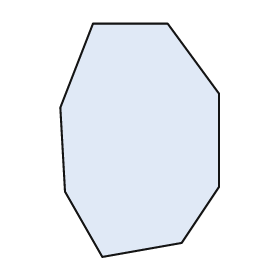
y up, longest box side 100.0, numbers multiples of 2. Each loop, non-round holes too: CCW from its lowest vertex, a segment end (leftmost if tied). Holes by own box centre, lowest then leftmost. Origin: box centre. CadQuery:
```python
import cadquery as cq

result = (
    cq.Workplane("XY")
    .moveTo(-16.0, -50.0)
    .lineTo(18.0, -44.0)
    .lineTo(34.0, -20.0)
    .lineTo(34.0, 20.0)
    .lineTo(12.0, 50.0)
    .lineTo(-20.0, 50.0)
    .lineTo(-34.0, 14.0)
    .lineTo(-32.0, -22.0)
    .close()
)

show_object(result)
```